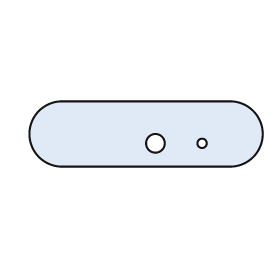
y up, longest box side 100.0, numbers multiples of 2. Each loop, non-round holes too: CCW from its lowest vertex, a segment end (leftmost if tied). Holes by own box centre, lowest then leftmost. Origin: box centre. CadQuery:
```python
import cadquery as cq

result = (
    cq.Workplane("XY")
    .moveTo(-36.0, -14.0)
    .lineTo(36.0, -14.0)
    .threePointArc((50.0, 0.0), (36.0, 14.0))
    .lineTo(-36.0, 14.0)
    .threePointArc((-50.0, 0.0), (-36.0, -14.0))
    .close()
    .moveTo(4.0, -4.0)
    .circle(4.0)
    .moveTo(24.0, -4.0)
    .circle(2.0)
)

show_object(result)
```